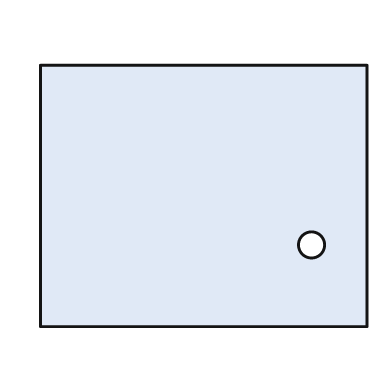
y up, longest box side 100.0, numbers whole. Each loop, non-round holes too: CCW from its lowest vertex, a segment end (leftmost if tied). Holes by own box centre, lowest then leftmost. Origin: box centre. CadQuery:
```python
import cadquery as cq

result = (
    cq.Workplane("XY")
    .moveTo(-50.0, -40.0)
    .lineTo(50.0, -40.0)
    .lineTo(50.0, 40.0)
    .lineTo(-50.0, 40.0)
    .close()
    .moveTo(33.0, -15.0)
    .circle(4.0)
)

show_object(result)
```